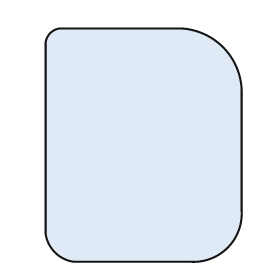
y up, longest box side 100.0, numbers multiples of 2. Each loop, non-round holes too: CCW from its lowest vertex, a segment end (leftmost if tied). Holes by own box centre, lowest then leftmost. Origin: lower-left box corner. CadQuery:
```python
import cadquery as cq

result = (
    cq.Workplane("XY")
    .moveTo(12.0, 0.0)
    .lineTo(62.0, 0.0)
    .threePointArc((78.0, 6.0), (84.0, 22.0))
    .lineTo(84.0, 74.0)
    .threePointArc((76.0, 92.0), (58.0, 100.0))
    .lineTo(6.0, 100.0)
    .threePointArc((2.0, 98.0), (0.0, 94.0))
    .lineTo(0.0, 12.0)
    .threePointArc((4.0, 4.0), (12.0, 0.0))
    .close()
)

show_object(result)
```